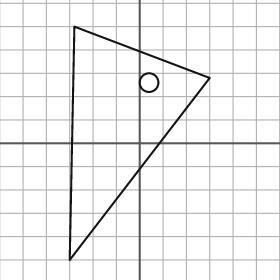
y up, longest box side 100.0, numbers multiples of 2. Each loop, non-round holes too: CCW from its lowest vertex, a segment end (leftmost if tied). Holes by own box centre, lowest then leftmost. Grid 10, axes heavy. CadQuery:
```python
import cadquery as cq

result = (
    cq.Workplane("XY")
    .moveTo(-30.0, -50.0)
    .lineTo(30.0, 28.0)
    .lineTo(-28.0, 50.0)
    .close()
    .moveTo(4.0, 26.0)
    .circle(4.0)
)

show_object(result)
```